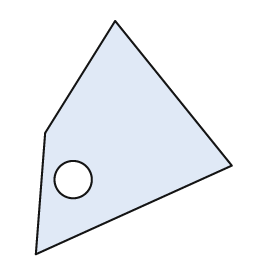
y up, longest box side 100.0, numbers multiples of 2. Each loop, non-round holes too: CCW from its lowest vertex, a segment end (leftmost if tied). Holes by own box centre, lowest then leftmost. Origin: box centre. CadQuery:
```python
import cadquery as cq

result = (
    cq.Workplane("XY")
    .moveTo(-42.0, -50.0)
    .lineTo(42.0, -12.0)
    .lineTo(-8.0, 50.0)
    .lineTo(-38.0, 2.0)
    .close()
    .moveTo(-26.0, -18.0)
    .circle(8.0)
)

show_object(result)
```